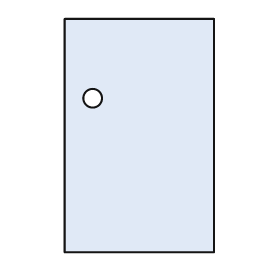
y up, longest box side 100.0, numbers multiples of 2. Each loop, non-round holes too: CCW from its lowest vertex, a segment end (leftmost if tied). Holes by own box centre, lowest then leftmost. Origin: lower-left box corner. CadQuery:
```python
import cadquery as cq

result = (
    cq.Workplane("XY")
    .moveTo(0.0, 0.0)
    .lineTo(64.0, 0.0)
    .lineTo(64.0, 100.0)
    .lineTo(0.0, 100.0)
    .close()
    .moveTo(12.0, 66.0)
    .circle(4.0)
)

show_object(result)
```